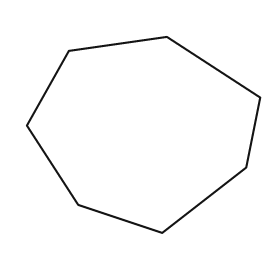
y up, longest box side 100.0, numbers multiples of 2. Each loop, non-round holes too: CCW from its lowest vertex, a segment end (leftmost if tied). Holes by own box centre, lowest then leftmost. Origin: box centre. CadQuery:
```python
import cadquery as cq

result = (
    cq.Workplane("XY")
    .moveTo(8.0, -42.0)
    .lineTo(44.0, -14.0)
    .lineTo(50.0, 16.0)
    .lineTo(10.0, 42.0)
    .lineTo(-32.0, 36.0)
    .lineTo(-50.0, 4.0)
    .lineTo(-28.0, -30.0)
    .close()
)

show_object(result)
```